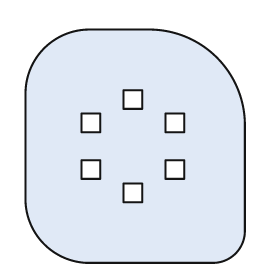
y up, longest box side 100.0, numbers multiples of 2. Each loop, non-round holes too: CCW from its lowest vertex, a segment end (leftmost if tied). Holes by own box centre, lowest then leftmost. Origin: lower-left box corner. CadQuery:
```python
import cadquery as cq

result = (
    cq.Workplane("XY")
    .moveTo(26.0, 0.0)
    .lineTo(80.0, 0.0)
    .threePointArc((90.0, 4.0), (94.0, 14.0))
    .lineTo(94.0, 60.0)
    .threePointArc((82.0, 88.0), (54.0, 100.0))
    .lineTo(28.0, 100.0)
    .threePointArc((8.0, 92.0), (0.0, 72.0))
    .lineTo(0.0, 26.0)
    .threePointArc((8.0, 8.0), (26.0, 0.0))
    .close()
    .moveTo(42.0, 26.0)
    .lineTo(50.0, 26.0)
    .lineTo(50.0, 34.0)
    .lineTo(42.0, 34.0)
    .close()
    .moveTo(24.0, 36.0)
    .lineTo(32.0, 36.0)
    .lineTo(32.0, 44.0)
    .lineTo(24.0, 44.0)
    .close()
    .moveTo(60.0, 36.0)
    .lineTo(68.0, 36.0)
    .lineTo(68.0, 44.0)
    .lineTo(60.0, 44.0)
    .close()
    .moveTo(24.0, 56.0)
    .lineTo(32.0, 56.0)
    .lineTo(32.0, 64.0)
    .lineTo(24.0, 64.0)
    .close()
    .moveTo(60.0, 56.0)
    .lineTo(68.0, 56.0)
    .lineTo(68.0, 64.0)
    .lineTo(60.0, 64.0)
    .close()
    .moveTo(42.0, 66.0)
    .lineTo(50.0, 66.0)
    .lineTo(50.0, 74.0)
    .lineTo(42.0, 74.0)
    .close()
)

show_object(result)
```